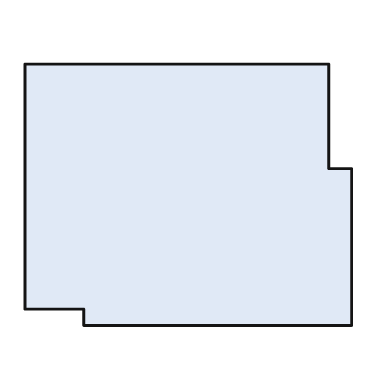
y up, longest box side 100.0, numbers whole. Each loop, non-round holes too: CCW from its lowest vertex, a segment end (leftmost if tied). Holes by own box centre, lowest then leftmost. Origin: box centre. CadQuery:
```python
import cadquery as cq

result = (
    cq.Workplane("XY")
    .moveTo(-32.0, -40.0)
    .lineTo(50.0, -40.0)
    .lineTo(50.0, 8.0)
    .lineTo(43.0, 8.0)
    .lineTo(43.0, 40.0)
    .lineTo(-50.0, 40.0)
    .lineTo(-50.0, -35.0)
    .lineTo(-32.0, -35.0)
    .close()
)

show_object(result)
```